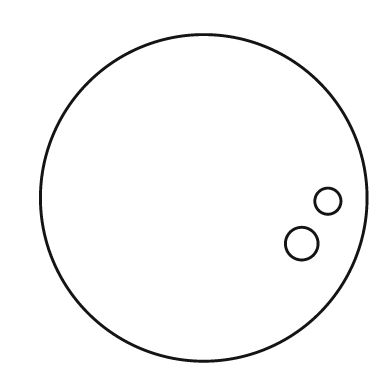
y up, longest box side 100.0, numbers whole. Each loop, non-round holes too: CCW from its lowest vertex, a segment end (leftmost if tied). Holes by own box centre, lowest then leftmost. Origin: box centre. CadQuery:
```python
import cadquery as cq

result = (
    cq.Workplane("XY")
    .moveTo(0.0, 0.0)
    .circle(50.0)
    .moveTo(30.0, -14.0)
    .circle(5.0)
    .moveTo(38.0, -1.0)
    .circle(4.0)
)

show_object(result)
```